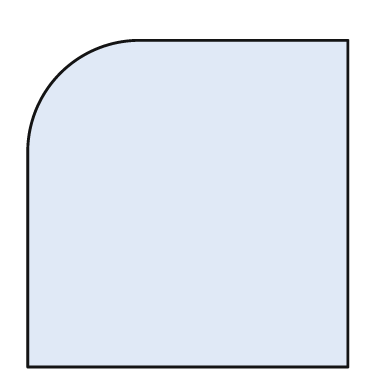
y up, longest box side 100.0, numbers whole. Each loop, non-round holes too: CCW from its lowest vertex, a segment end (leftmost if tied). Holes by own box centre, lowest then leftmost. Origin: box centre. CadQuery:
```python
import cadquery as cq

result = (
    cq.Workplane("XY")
    .moveTo(-49.0, -50.0)
    .lineTo(49.0, -50.0)
    .lineTo(49.0, 50.0)
    .lineTo(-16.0, 50.0)
    .threePointArc((-39.0, 40.0), (-49.0, 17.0))
    .close()
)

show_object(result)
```